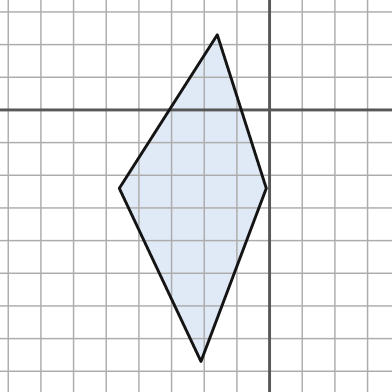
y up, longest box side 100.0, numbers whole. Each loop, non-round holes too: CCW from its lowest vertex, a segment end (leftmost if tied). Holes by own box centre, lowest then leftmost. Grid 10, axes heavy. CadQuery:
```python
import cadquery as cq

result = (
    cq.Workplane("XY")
    .moveTo(-21.0, -77.0)
    .lineTo(-1.0, -24.0)
    .lineTo(-16.0, 23.0)
    .lineTo(-46.0, -24.0)
    .close()
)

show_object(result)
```